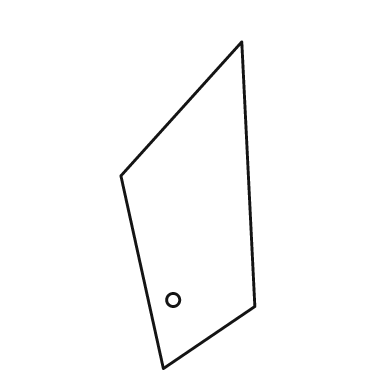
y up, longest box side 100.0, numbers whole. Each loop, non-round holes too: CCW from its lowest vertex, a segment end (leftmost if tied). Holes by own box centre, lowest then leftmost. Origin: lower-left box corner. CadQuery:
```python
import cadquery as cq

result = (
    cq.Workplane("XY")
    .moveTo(13.0, 0.0)
    .lineTo(41.0, 19.0)
    .lineTo(37.0, 100.0)
    .lineTo(0.0, 59.0)
    .close()
    .moveTo(16.0, 21.0)
    .circle(2.0)
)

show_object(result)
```